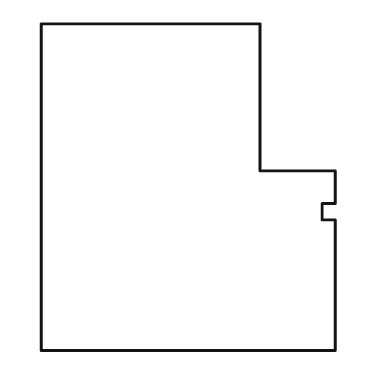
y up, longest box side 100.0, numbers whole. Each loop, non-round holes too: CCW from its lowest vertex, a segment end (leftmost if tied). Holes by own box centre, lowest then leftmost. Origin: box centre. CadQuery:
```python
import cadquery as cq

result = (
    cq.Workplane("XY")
    .moveTo(-45.0, -50.0)
    .lineTo(45.0, -50.0)
    .lineTo(45.0, -10.0)
    .lineTo(41.0, -10.0)
    .lineTo(41.0, -5.0)
    .lineTo(45.0, -5.0)
    .lineTo(45.0, 5.0)
    .lineTo(22.0, 5.0)
    .lineTo(22.0, 50.0)
    .lineTo(-45.0, 50.0)
    .close()
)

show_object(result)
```